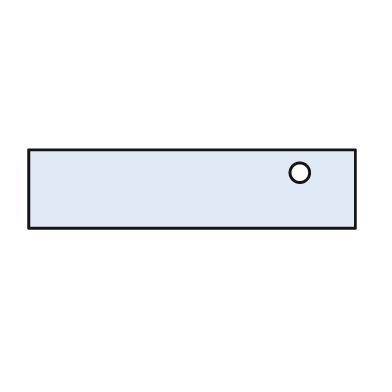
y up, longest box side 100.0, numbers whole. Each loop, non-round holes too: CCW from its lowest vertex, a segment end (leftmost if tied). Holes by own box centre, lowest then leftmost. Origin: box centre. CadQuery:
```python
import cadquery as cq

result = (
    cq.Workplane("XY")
    .moveTo(-50.0, -12.0)
    .lineTo(50.0, -12.0)
    .lineTo(50.0, 12.0)
    .lineTo(-50.0, 12.0)
    .close()
    .moveTo(33.0, 5.0)
    .circle(3.0)
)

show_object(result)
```